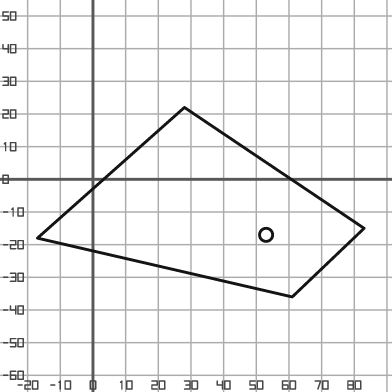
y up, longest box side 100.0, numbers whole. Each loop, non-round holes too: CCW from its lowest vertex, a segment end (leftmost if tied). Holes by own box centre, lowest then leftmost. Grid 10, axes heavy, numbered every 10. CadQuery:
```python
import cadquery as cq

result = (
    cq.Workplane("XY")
    .moveTo(61.0, -36.0)
    .lineTo(83.0, -15.0)
    .lineTo(28.0, 22.0)
    .lineTo(-17.0, -18.0)
    .close()
    .moveTo(53.0, -17.0)
    .circle(2.0)
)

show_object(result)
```